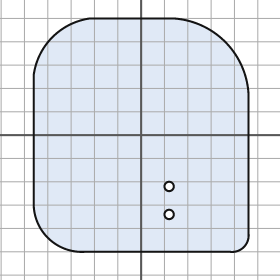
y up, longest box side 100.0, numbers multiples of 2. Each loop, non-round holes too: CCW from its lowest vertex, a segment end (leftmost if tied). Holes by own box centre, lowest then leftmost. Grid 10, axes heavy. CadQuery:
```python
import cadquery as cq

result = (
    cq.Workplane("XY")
    .moveTo(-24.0, -50.0)
    .lineTo(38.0, -50.0)
    .threePointArc((44.0, -48.0), (46.0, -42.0))
    .lineTo(46.0, 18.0)
    .threePointArc((36.0, 40.0), (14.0, 50.0))
    .lineTo(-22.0, 50.0)
    .threePointArc((-38.0, 42.0), (-46.0, 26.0))
    .lineTo(-46.0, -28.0)
    .threePointArc((-40.0, -44.0), (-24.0, -50.0))
    .close()
    .moveTo(12.0, -34.0)
    .circle(2.0)
    .moveTo(12.0, -22.0)
    .circle(2.0)
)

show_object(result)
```